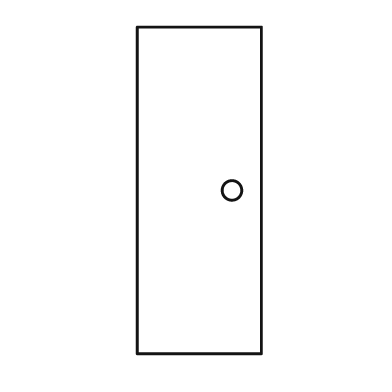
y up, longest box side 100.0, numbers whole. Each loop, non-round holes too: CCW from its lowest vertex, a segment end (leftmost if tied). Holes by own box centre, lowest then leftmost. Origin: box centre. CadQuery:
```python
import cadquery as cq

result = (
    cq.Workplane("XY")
    .moveTo(-19.0, -50.0)
    .lineTo(19.0, -50.0)
    .lineTo(19.0, 50.0)
    .lineTo(-19.0, 50.0)
    .close()
    .moveTo(10.0, 0.0)
    .circle(3.0)
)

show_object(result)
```